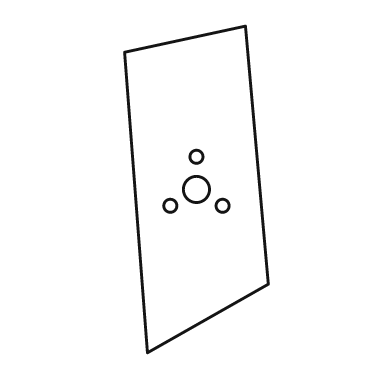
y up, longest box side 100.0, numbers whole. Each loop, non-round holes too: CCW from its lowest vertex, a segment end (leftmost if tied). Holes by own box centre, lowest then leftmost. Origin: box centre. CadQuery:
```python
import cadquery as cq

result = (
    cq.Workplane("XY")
    .moveTo(-15.0, -50.0)
    .lineTo(22.0, -29.0)
    .lineTo(15.0, 50.0)
    .lineTo(-22.0, 42.0)
    .close()
    .moveTo(-8.0, -5.0)
    .circle(2.0)
    .moveTo(8.0, -5.0)
    .circle(2.0)
    .moveTo(0.0, 0.0)
    .circle(4.0)
    .moveTo(0.0, 10.0)
    .circle(2.0)
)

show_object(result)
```